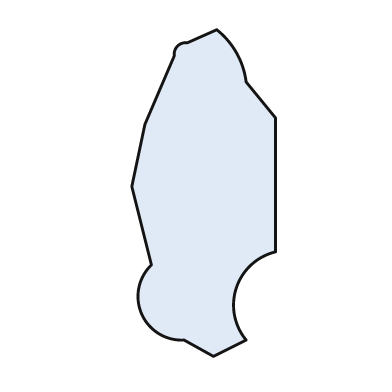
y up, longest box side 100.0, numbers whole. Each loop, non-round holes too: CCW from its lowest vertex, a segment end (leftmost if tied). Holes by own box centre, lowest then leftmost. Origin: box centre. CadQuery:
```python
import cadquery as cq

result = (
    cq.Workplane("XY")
    .moveTo(3.0, -50.0)
    .lineTo(13.0, -45.0)
    .threePointArc((10.0, -29.0), (22.0, -18.0))
    .lineTo(22.0, 23.0)
    .lineTo(13.0, 34.0)
    .threePointArc((10.0, 43.0), (4.0, 50.0))
    .lineTo(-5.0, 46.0)
    .threePointArc((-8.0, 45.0), (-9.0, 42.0))
    .lineTo(-18.0, 21.0)
    .lineTo(-22.0, 2.0)
    .lineTo(-16.0, -22.0)
    .threePointArc((-19.0, -37.0), (-6.0, -45.0))
    .close()
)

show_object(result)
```